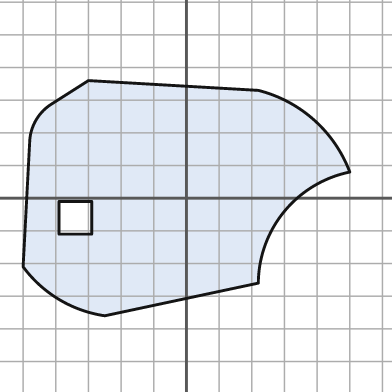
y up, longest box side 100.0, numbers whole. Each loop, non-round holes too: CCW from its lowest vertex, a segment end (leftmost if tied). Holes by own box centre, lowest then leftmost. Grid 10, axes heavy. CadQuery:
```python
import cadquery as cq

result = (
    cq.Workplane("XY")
    .moveTo(-25.0, -36.0)
    .lineTo(22.0, -26.0)
    .threePointArc((30.0, -4.0), (50.0, 8.0))
    .threePointArc((39.0, 24.0), (22.0, 33.0))
    .lineTo(-30.0, 36.0)
    .lineTo(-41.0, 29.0)
    .threePointArc((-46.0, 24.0), (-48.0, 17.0))
    .lineTo(-50.0, -21.0)
    .threePointArc((-39.0, -31.0), (-25.0, -36.0))
    .close()
    .moveTo(-39.0, -11.0)
    .lineTo(-29.0, -11.0)
    .lineTo(-29.0, -1.0)
    .lineTo(-39.0, -1.0)
    .close()
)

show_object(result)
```